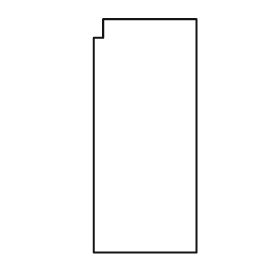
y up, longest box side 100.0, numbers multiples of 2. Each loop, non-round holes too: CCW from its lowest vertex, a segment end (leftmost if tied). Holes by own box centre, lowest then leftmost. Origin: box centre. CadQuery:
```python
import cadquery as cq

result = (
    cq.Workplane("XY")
    .moveTo(-22.0, -50.0)
    .lineTo(22.0, -50.0)
    .lineTo(22.0, 50.0)
    .lineTo(-18.0, 50.0)
    .lineTo(-18.0, 42.0)
    .lineTo(-22.0, 42.0)
    .close()
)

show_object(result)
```